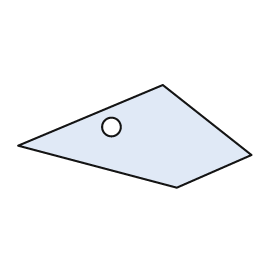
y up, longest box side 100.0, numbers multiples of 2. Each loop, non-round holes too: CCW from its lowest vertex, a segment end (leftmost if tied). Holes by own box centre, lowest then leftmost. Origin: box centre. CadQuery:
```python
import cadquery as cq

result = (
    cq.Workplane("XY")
    .moveTo(18.0, -22.0)
    .lineTo(50.0, -8.0)
    .lineTo(12.0, 22.0)
    .lineTo(-50.0, -4.0)
    .close()
    .moveTo(-10.0, 4.0)
    .circle(4.0)
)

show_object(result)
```